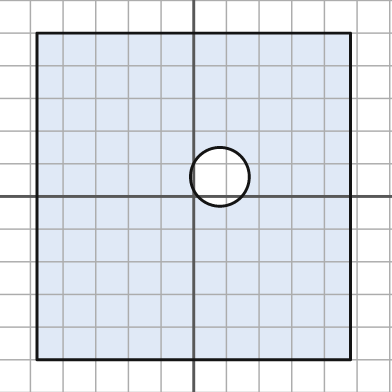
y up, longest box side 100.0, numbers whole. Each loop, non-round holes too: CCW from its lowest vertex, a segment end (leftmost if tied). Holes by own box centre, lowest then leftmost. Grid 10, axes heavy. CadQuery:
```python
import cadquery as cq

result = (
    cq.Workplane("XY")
    .moveTo(-48.0, -50.0)
    .lineTo(48.0, -50.0)
    .lineTo(48.0, 50.0)
    .lineTo(-48.0, 50.0)
    .close()
    .moveTo(8.0, 6.0)
    .circle(9.0)
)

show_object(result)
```